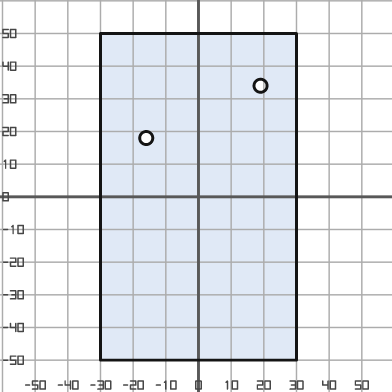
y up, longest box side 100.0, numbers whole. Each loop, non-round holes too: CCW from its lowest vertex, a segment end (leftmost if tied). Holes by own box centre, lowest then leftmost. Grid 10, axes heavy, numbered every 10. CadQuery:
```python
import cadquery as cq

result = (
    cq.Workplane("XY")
    .moveTo(-30.0, -50.0)
    .lineTo(30.0, -50.0)
    .lineTo(30.0, 50.0)
    .lineTo(-30.0, 50.0)
    .close()
    .moveTo(-16.0, 18.0)
    .circle(2.0)
    .moveTo(19.0, 34.0)
    .circle(2.0)
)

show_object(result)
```